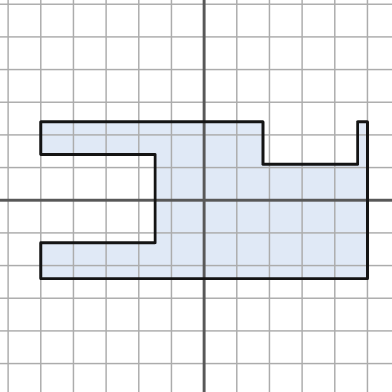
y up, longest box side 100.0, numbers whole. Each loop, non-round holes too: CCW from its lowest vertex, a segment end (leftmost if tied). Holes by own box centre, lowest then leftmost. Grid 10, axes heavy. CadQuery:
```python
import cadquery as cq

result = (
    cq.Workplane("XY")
    .moveTo(-50.0, -24.0)
    .lineTo(50.0, -24.0)
    .lineTo(50.0, 24.0)
    .lineTo(47.0, 24.0)
    .lineTo(47.0, 11.0)
    .lineTo(18.0, 11.0)
    .lineTo(18.0, 24.0)
    .lineTo(-50.0, 24.0)
    .lineTo(-50.0, 14.0)
    .lineTo(-15.0, 14.0)
    .lineTo(-15.0, -13.0)
    .lineTo(-50.0, -13.0)
    .close()
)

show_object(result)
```